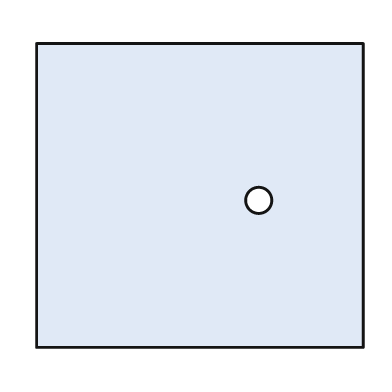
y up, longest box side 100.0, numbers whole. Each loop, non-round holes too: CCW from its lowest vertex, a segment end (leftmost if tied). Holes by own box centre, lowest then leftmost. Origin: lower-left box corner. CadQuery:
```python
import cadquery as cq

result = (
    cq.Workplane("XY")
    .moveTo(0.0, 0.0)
    .lineTo(100.0, 0.0)
    .lineTo(100.0, 93.0)
    .lineTo(0.0, 93.0)
    .close()
    .moveTo(68.0, 45.0)
    .circle(4.0)
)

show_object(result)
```